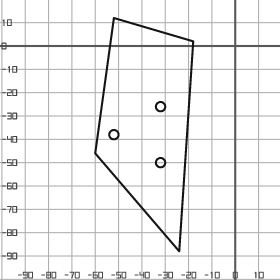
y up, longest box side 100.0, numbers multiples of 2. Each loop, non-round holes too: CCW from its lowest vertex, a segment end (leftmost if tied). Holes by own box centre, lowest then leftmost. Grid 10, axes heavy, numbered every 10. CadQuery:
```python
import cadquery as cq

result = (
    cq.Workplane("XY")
    .moveTo(-24.0, -88.0)
    .lineTo(-18.0, 2.0)
    .lineTo(-52.0, 12.0)
    .lineTo(-60.0, -46.0)
    .close()
    .moveTo(-32.0, -50.0)
    .circle(2.0)
    .moveTo(-52.0, -38.0)
    .circle(2.0)
    .moveTo(-32.0, -26.0)
    .circle(2.0)
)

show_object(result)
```